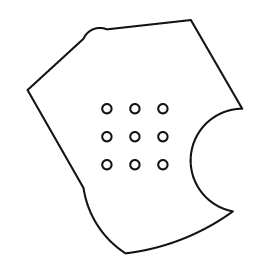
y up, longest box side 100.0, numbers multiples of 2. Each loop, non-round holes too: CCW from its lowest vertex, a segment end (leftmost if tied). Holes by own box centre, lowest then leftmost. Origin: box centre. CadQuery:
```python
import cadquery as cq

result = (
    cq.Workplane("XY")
    .moveTo(-4.0, -50.0)
    .threePointArc((20.0, -44.0), (42.0, -32.0))
    .threePointArc((24.0, -8.0), (46.0, 12.0))
    .lineTo(24.0, 50.0)
    .lineTo(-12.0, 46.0)
    .threePointArc((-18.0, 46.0), (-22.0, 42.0))
    .lineTo(-46.0, 20.0)
    .lineTo(-22.0, -22.0)
    .threePointArc((-16.0, -38.0), (-4.0, -50.0))
    .close()
    .moveTo(-12.0, -12.0)
    .circle(2.0)
    .moveTo(0.0, -12.0)
    .circle(2.0)
    .moveTo(12.0, -12.0)
    .circle(2.0)
    .moveTo(-12.0, 0.0)
    .circle(2.0)
    .moveTo(0.0, 0.0)
    .circle(2.0)
    .moveTo(12.0, 0.0)
    .circle(2.0)
    .moveTo(-12.0, 12.0)
    .circle(2.0)
    .moveTo(0.0, 12.0)
    .circle(2.0)
    .moveTo(12.0, 12.0)
    .circle(2.0)
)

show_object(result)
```